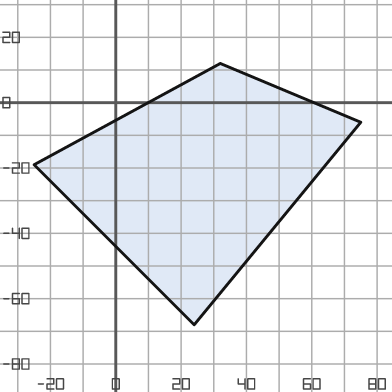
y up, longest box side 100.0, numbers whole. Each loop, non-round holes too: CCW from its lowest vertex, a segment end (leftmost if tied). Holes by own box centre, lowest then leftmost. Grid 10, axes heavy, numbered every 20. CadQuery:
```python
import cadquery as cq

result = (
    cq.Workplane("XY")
    .moveTo(24.0, -68.0)
    .lineTo(75.0, -6.0)
    .lineTo(32.0, 12.0)
    .lineTo(-25.0, -19.0)
    .close()
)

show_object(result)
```